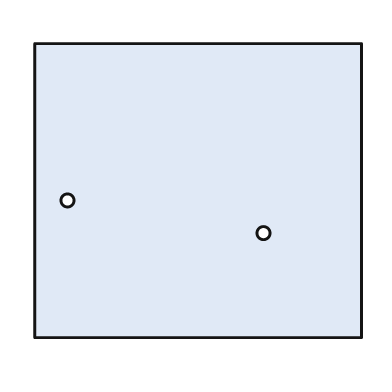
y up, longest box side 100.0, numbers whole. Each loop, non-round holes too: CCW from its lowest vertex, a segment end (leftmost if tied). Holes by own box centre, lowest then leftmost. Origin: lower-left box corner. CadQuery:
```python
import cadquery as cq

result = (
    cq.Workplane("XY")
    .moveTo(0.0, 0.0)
    .lineTo(100.0, 0.0)
    .lineTo(100.0, 90.0)
    .lineTo(0.0, 90.0)
    .close()
    .moveTo(70.0, 32.0)
    .circle(2.0)
    .moveTo(10.0, 42.0)
    .circle(2.0)
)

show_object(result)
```